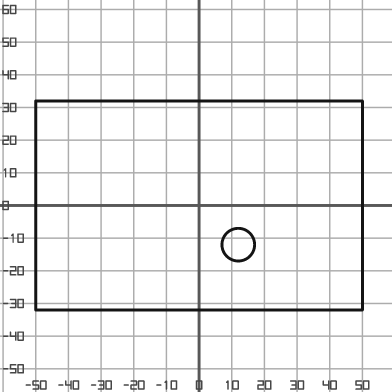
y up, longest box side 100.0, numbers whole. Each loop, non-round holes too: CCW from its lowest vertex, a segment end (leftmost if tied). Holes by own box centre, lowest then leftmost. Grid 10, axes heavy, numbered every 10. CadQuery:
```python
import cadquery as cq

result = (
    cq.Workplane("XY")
    .moveTo(-50.0, -32.0)
    .lineTo(50.0, -32.0)
    .lineTo(50.0, 32.0)
    .lineTo(-50.0, 32.0)
    .close()
    .moveTo(12.0, -12.0)
    .circle(5.0)
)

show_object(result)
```